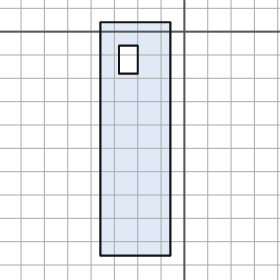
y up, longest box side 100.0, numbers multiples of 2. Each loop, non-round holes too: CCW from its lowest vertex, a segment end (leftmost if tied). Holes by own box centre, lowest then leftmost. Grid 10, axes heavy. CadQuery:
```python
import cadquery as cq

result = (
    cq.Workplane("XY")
    .moveTo(-36.0, -96.0)
    .lineTo(-6.0, -96.0)
    .lineTo(-6.0, 4.0)
    .lineTo(-36.0, 4.0)
    .close()
    .moveTo(-28.0, -18.0)
    .lineTo(-20.0, -18.0)
    .lineTo(-20.0, -6.0)
    .lineTo(-28.0, -6.0)
    .close()
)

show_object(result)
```